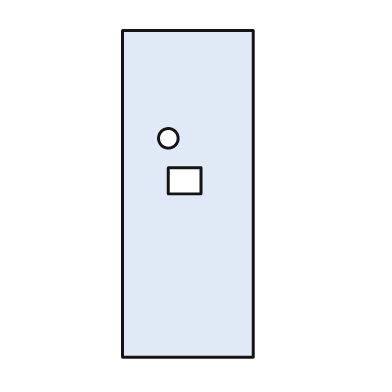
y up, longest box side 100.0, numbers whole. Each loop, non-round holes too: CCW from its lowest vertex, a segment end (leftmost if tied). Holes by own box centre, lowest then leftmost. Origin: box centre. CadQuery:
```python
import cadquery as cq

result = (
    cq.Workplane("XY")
    .moveTo(-20.0, -50.0)
    .lineTo(20.0, -50.0)
    .lineTo(20.0, 50.0)
    .lineTo(-20.0, 50.0)
    .close()
    .moveTo(-6.0, 0.0)
    .lineTo(4.0, 0.0)
    .lineTo(4.0, 8.0)
    .lineTo(-6.0, 8.0)
    .close()
    .moveTo(-6.0, 17.0)
    .circle(3.0)
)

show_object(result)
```